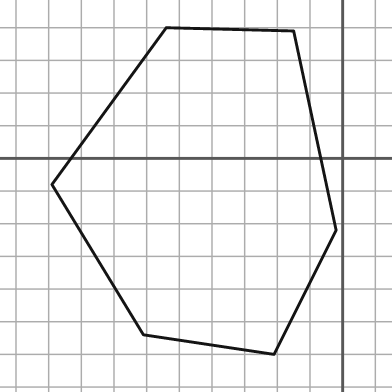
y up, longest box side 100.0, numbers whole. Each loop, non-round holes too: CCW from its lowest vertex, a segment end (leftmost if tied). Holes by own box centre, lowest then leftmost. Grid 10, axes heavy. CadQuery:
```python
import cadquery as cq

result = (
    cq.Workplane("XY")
    .moveTo(-21.0, -60.0)
    .lineTo(-2.0, -22.0)
    .lineTo(-15.0, 39.0)
    .lineTo(-54.0, 40.0)
    .lineTo(-89.0, -8.0)
    .lineTo(-61.0, -54.0)
    .close()
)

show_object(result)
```